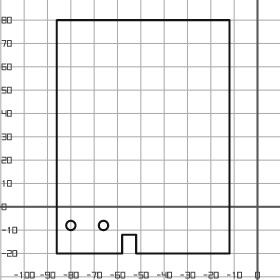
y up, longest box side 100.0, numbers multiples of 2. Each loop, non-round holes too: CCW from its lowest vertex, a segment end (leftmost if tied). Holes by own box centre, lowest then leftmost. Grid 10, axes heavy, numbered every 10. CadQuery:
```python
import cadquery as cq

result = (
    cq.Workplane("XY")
    .moveTo(-86.0, -20.0)
    .lineTo(-58.0, -20.0)
    .lineTo(-58.0, -12.0)
    .lineTo(-52.0, -12.0)
    .lineTo(-52.0, -20.0)
    .lineTo(-12.0, -20.0)
    .lineTo(-12.0, 80.0)
    .lineTo(-86.0, 80.0)
    .close()
    .moveTo(-80.0, -8.0)
    .circle(2.0)
    .moveTo(-66.0, -8.0)
    .circle(2.0)
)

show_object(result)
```